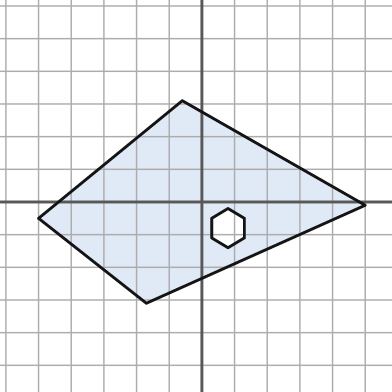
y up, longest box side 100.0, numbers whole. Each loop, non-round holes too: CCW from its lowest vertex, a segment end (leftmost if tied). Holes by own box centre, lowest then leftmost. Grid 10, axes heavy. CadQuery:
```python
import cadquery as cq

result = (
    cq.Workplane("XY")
    .moveTo(-17.0, -31.0)
    .lineTo(50.0, -1.0)
    .lineTo(-6.0, 31.0)
    .lineTo(-50.0, -5.0)
    .close()
    .moveTo(8.0, -14.0)
    .lineTo(13.0, -11.0)
    .lineTo(13.0, -5.0)
    .lineTo(8.0, -2.0)
    .lineTo(3.0, -5.0)
    .lineTo(3.0, -11.0)
    .close()
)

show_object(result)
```